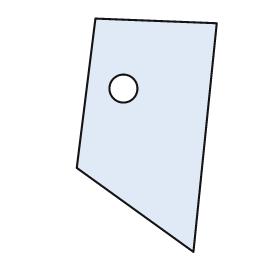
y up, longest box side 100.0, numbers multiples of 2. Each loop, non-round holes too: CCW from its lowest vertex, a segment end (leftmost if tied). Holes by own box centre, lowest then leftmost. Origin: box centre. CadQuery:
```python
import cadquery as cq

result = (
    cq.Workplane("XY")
    .moveTo(20.0, -50.0)
    .lineTo(30.0, 48.0)
    .lineTo(-22.0, 50.0)
    .lineTo(-30.0, -14.0)
    .close()
    .moveTo(-10.0, 20.0)
    .circle(6.0)
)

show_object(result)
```